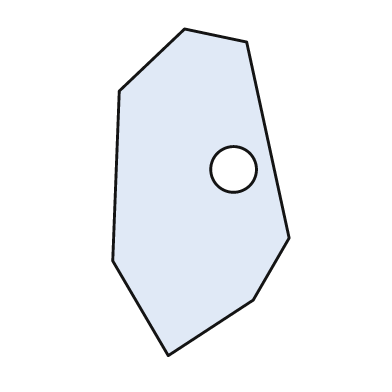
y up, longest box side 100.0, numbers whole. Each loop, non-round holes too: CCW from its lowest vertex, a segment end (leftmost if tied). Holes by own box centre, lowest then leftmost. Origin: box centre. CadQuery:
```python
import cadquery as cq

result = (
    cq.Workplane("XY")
    .moveTo(-10.0, -50.0)
    .lineTo(16.0, -33.0)
    .lineTo(27.0, -14.0)
    .lineTo(14.0, 46.0)
    .lineTo(-5.0, 50.0)
    .lineTo(-25.0, 31.0)
    .lineTo(-27.0, -21.0)
    .close()
    .moveTo(10.0, 7.0)
    .circle(7.0)
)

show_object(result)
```